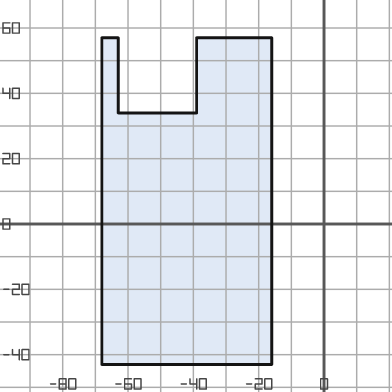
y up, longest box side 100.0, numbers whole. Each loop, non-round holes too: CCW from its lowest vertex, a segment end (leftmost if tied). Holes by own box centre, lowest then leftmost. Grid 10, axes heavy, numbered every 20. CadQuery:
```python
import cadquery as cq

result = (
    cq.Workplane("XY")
    .moveTo(-68.0, -43.0)
    .lineTo(-16.0, -43.0)
    .lineTo(-16.0, 57.0)
    .lineTo(-39.0, 57.0)
    .lineTo(-39.0, 34.0)
    .lineTo(-63.0, 34.0)
    .lineTo(-63.0, 57.0)
    .lineTo(-68.0, 57.0)
    .close()
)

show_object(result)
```